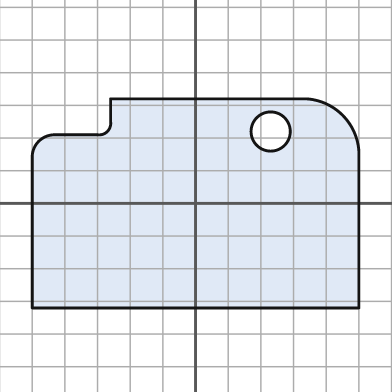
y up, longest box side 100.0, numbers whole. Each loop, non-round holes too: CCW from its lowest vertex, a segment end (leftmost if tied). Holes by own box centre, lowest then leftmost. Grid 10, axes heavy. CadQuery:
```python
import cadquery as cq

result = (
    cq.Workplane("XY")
    .moveTo(-50.0, -32.0)
    .lineTo(50.0, -32.0)
    .lineTo(50.0, 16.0)
    .threePointArc((45.0, 27.0), (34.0, 32.0))
    .lineTo(-26.0, 32.0)
    .lineTo(-26.0, 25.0)
    .threePointArc((-27.0, 22.0), (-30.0, 21.0))
    .lineTo(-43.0, 21.0)
    .threePointArc((-48.0, 19.0), (-50.0, 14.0))
    .close()
    .moveTo(23.0, 22.0)
    .circle(6.0)
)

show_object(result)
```